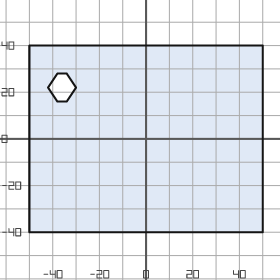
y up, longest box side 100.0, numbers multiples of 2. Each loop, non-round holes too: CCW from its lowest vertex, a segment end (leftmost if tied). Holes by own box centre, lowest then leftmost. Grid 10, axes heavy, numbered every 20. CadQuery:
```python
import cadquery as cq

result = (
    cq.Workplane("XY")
    .moveTo(-50.0, -40.0)
    .lineTo(50.0, -40.0)
    .lineTo(50.0, 40.0)
    .lineTo(-50.0, 40.0)
    .close()
    .moveTo(-38.0, 16.0)
    .lineTo(-34.0, 16.0)
    .lineTo(-30.0, 22.0)
    .lineTo(-34.0, 28.0)
    .lineTo(-38.0, 28.0)
    .lineTo(-42.0, 22.0)
    .close()
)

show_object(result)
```